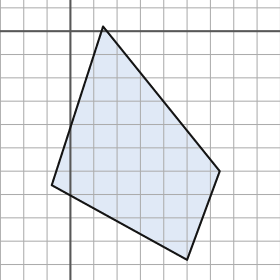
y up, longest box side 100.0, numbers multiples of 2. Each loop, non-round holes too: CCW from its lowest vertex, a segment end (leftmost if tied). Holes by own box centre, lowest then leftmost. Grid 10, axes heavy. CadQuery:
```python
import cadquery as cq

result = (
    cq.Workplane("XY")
    .moveTo(50.0, -98.0)
    .lineTo(64.0, -60.0)
    .lineTo(14.0, 2.0)
    .lineTo(-8.0, -66.0)
    .close()
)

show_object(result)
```